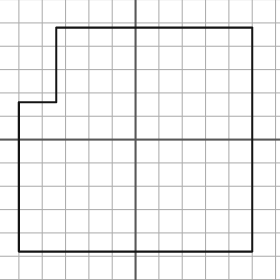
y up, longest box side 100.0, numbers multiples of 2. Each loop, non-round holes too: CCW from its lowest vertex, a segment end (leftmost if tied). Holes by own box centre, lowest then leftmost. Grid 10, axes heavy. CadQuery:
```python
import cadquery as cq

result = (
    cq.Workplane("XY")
    .moveTo(-50.0, -48.0)
    .lineTo(50.0, -48.0)
    .lineTo(50.0, 48.0)
    .lineTo(-34.0, 48.0)
    .lineTo(-34.0, 16.0)
    .lineTo(-50.0, 16.0)
    .close()
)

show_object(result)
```